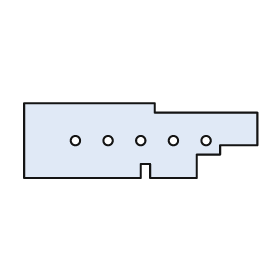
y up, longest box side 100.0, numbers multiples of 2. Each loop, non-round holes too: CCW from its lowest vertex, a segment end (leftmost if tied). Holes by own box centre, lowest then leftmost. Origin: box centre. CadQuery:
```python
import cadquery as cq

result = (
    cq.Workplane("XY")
    .moveTo(-50.0, -16.0)
    .lineTo(0.0, -16.0)
    .lineTo(0.0, -10.0)
    .lineTo(4.0, -10.0)
    .lineTo(4.0, -16.0)
    .lineTo(24.0, -16.0)
    .lineTo(24.0, -6.0)
    .lineTo(34.0, -6.0)
    .lineTo(34.0, -2.0)
    .lineTo(50.0, -2.0)
    .lineTo(50.0, 12.0)
    .lineTo(6.0, 12.0)
    .lineTo(6.0, 16.0)
    .lineTo(-50.0, 16.0)
    .close()
    .moveTo(-28.0, 0.0)
    .circle(2.0)
    .moveTo(-14.0, 0.0)
    .circle(2.0)
    .moveTo(0.0, 0.0)
    .circle(2.0)
    .moveTo(14.0, 0.0)
    .circle(2.0)
    .moveTo(28.0, 0.0)
    .circle(2.0)
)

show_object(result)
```